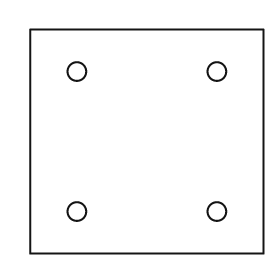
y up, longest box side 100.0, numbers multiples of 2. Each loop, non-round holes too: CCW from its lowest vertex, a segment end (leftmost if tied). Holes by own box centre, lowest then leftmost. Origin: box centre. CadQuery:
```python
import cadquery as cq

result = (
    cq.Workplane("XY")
    .moveTo(-50.0, -48.0)
    .lineTo(50.0, -48.0)
    .lineTo(50.0, 48.0)
    .lineTo(-50.0, 48.0)
    .close()
    .moveTo(-30.0, -30.0)
    .circle(4.0)
    .moveTo(30.0, -30.0)
    .circle(4.0)
    .moveTo(-30.0, 30.0)
    .circle(4.0)
    .moveTo(30.0, 30.0)
    .circle(4.0)
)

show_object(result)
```